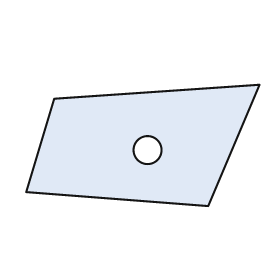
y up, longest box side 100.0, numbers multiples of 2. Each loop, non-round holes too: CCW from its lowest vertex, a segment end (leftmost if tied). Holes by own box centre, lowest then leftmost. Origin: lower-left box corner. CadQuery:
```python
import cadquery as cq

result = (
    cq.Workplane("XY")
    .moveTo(78.0, 0.0)
    .lineTo(100.0, 52.0)
    .lineTo(12.0, 46.0)
    .lineTo(0.0, 6.0)
    .close()
    .moveTo(52.0, 24.0)
    .circle(6.0)
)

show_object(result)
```